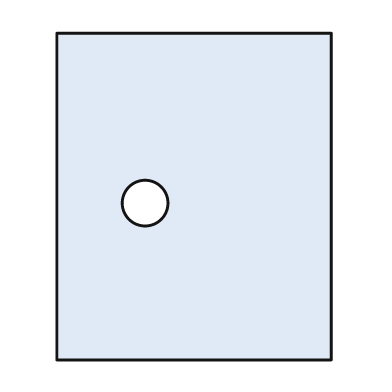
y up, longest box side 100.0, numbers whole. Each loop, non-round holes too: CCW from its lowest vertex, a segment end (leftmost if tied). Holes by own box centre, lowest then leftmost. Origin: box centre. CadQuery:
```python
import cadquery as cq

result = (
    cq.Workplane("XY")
    .moveTo(-42.0, -50.0)
    .lineTo(42.0, -50.0)
    .lineTo(42.0, 50.0)
    .lineTo(-42.0, 50.0)
    .close()
    .moveTo(-15.0, -2.0)
    .circle(7.0)
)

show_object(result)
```